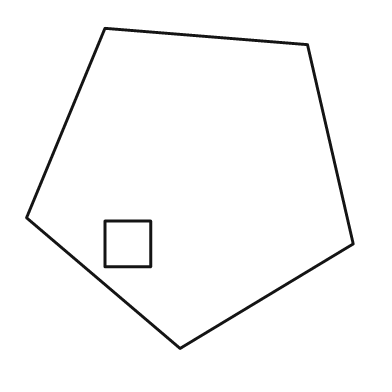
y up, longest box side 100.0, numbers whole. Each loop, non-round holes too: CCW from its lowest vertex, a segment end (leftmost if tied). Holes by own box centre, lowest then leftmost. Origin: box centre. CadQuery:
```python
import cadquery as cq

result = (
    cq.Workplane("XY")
    .moveTo(-3.0, -49.0)
    .lineTo(50.0, -17.0)
    .lineTo(36.0, 44.0)
    .lineTo(-26.0, 49.0)
    .lineTo(-50.0, -9.0)
    .close()
    .moveTo(-26.0, -24.0)
    .lineTo(-12.0, -24.0)
    .lineTo(-12.0, -10.0)
    .lineTo(-26.0, -10.0)
    .close()
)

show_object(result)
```